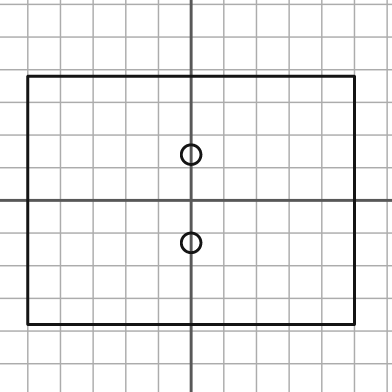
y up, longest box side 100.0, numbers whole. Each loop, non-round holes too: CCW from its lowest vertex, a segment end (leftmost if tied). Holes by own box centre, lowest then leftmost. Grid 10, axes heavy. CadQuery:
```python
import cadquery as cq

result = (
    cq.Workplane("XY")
    .moveTo(-50.0, -38.0)
    .lineTo(50.0, -38.0)
    .lineTo(50.0, 38.0)
    .lineTo(-50.0, 38.0)
    .close()
    .moveTo(0.0, -13.0)
    .circle(3.0)
    .moveTo(0.0, 14.0)
    .circle(3.0)
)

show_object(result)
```